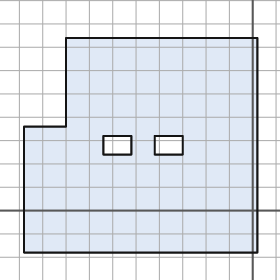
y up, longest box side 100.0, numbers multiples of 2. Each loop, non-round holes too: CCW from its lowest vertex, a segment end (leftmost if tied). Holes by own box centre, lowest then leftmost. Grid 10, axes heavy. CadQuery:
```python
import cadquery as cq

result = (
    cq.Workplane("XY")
    .moveTo(-98.0, -18.0)
    .lineTo(2.0, -18.0)
    .lineTo(2.0, 74.0)
    .lineTo(-80.0, 74.0)
    .lineTo(-80.0, 36.0)
    .lineTo(-98.0, 36.0)
    .close()
    .moveTo(-64.0, 24.0)
    .lineTo(-52.0, 24.0)
    .lineTo(-52.0, 32.0)
    .lineTo(-64.0, 32.0)
    .close()
    .moveTo(-42.0, 24.0)
    .lineTo(-30.0, 24.0)
    .lineTo(-30.0, 32.0)
    .lineTo(-42.0, 32.0)
    .close()
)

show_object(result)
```